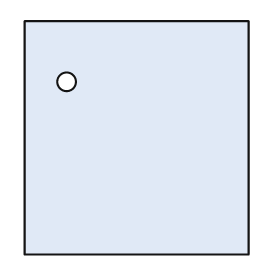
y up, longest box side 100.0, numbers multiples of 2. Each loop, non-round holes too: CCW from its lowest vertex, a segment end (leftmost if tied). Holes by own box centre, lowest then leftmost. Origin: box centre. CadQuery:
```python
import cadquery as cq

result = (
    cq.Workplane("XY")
    .moveTo(-48.0, -50.0)
    .lineTo(48.0, -50.0)
    .lineTo(48.0, 50.0)
    .lineTo(-48.0, 50.0)
    .close()
    .moveTo(-30.0, 24.0)
    .circle(4.0)
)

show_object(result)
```